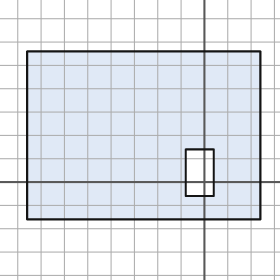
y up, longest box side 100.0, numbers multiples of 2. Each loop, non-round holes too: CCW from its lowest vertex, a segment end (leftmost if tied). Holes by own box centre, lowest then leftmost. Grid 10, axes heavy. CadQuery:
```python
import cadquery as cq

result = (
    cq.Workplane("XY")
    .moveTo(-76.0, -16.0)
    .lineTo(24.0, -16.0)
    .lineTo(24.0, 56.0)
    .lineTo(-76.0, 56.0)
    .close()
    .moveTo(-8.0, -6.0)
    .lineTo(4.0, -6.0)
    .lineTo(4.0, 14.0)
    .lineTo(-8.0, 14.0)
    .close()
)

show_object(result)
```